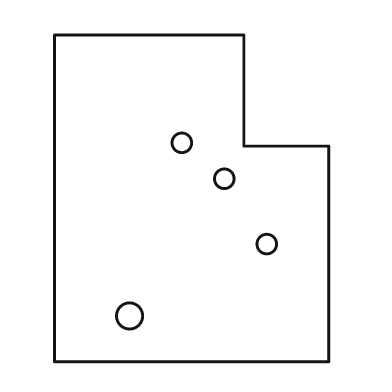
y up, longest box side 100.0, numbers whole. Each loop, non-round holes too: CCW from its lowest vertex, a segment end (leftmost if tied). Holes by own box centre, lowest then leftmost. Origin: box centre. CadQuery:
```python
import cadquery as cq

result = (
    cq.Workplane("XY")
    .moveTo(-42.0, -50.0)
    .lineTo(42.0, -50.0)
    .lineTo(42.0, 16.0)
    .lineTo(16.0, 16.0)
    .lineTo(16.0, 50.0)
    .lineTo(-42.0, 50.0)
    .close()
    .moveTo(-19.0, -36.0)
    .circle(4.0)
    .moveTo(23.0, -14.0)
    .circle(3.0)
    .moveTo(10.0, 6.0)
    .circle(3.0)
    .moveTo(-3.0, 17.0)
    .circle(3.0)
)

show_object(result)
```